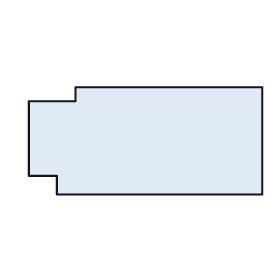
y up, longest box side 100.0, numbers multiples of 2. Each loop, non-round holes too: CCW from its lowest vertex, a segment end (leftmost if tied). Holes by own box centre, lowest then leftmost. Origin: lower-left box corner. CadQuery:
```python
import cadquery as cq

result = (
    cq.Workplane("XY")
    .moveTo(12.0, 0.0)
    .lineTo(100.0, 0.0)
    .lineTo(100.0, 46.0)
    .lineTo(20.0, 46.0)
    .lineTo(20.0, 40.0)
    .lineTo(0.0, 40.0)
    .lineTo(0.0, 8.0)
    .lineTo(12.0, 8.0)
    .close()
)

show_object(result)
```